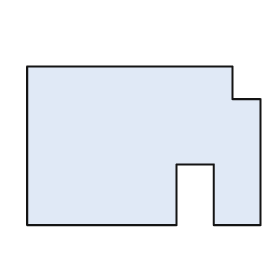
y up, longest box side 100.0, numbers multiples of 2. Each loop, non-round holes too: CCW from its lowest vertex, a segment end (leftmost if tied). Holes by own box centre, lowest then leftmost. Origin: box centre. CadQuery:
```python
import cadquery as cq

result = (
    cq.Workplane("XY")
    .moveTo(-50.0, -34.0)
    .lineTo(14.0, -34.0)
    .lineTo(14.0, -8.0)
    .lineTo(30.0, -8.0)
    .lineTo(30.0, -34.0)
    .lineTo(50.0, -34.0)
    .lineTo(50.0, 20.0)
    .lineTo(38.0, 20.0)
    .lineTo(38.0, 34.0)
    .lineTo(-50.0, 34.0)
    .close()
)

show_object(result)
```